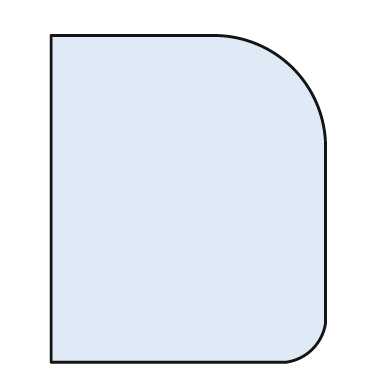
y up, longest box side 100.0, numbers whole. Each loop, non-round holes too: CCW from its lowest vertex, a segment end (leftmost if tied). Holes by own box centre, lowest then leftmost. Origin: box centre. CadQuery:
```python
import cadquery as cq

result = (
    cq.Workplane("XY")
    .moveTo(-42.0, -50.0)
    .lineTo(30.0, -50.0)
    .threePointArc((38.0, -46.0), (42.0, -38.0))
    .lineTo(42.0, 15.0)
    .threePointArc((32.0, 40.0), (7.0, 50.0))
    .lineTo(-42.0, 50.0)
    .close()
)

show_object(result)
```